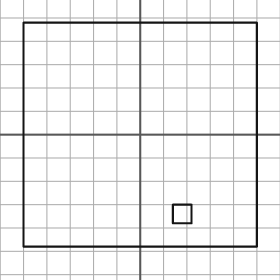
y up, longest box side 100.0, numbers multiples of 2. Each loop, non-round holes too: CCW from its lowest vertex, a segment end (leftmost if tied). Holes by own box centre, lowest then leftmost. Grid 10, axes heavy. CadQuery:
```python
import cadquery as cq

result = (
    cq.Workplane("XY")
    .moveTo(-50.0, -48.0)
    .lineTo(50.0, -48.0)
    .lineTo(50.0, 48.0)
    .lineTo(-50.0, 48.0)
    .close()
    .moveTo(14.0, -38.0)
    .lineTo(22.0, -38.0)
    .lineTo(22.0, -30.0)
    .lineTo(14.0, -30.0)
    .close()
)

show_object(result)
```